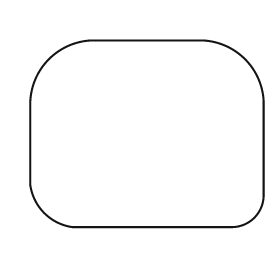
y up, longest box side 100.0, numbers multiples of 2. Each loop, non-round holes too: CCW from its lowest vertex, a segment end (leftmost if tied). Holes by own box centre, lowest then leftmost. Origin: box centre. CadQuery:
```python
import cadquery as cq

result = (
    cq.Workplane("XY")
    .moveTo(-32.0, -40.0)
    .lineTo(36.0, -40.0)
    .threePointArc((46.0, -36.0), (50.0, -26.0))
    .lineTo(50.0, 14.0)
    .threePointArc((42.0, 32.0), (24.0, 40.0))
    .lineTo(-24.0, 40.0)
    .threePointArc((-42.0, 32.0), (-50.0, 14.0))
    .lineTo(-50.0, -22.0)
    .threePointArc((-44.0, -34.0), (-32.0, -40.0))
    .close()
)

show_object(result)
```